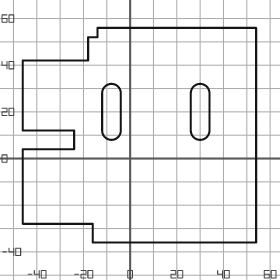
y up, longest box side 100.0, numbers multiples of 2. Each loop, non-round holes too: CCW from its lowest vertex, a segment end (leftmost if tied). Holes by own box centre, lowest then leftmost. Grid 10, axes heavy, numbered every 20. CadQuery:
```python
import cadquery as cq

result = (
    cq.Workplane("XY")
    .moveTo(-16.0, -36.0)
    .lineTo(54.0, -36.0)
    .lineTo(54.0, 56.0)
    .lineTo(-14.0, 56.0)
    .lineTo(-14.0, 52.0)
    .lineTo(-18.0, 52.0)
    .lineTo(-18.0, 42.0)
    .lineTo(-46.0, 42.0)
    .lineTo(-46.0, 12.0)
    .lineTo(-24.0, 12.0)
    .lineTo(-24.0, 4.0)
    .lineTo(-46.0, 4.0)
    .lineTo(-46.0, -28.0)
    .lineTo(-16.0, -28.0)
    .close()
    .moveTo(-12.0, 12.0)
    .threePointArc((-8.0, 8.0), (-4.0, 12.0))
    .lineTo(-4.0, 28.0)
    .threePointArc((-8.0, 32.0), (-12.0, 28.0))
    .close()
    .moveTo(26.0, 12.0)
    .threePointArc((30.0, 8.0), (34.0, 12.0))
    .lineTo(34.0, 28.0)
    .threePointArc((30.0, 32.0), (26.0, 28.0))
    .close()
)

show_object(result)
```